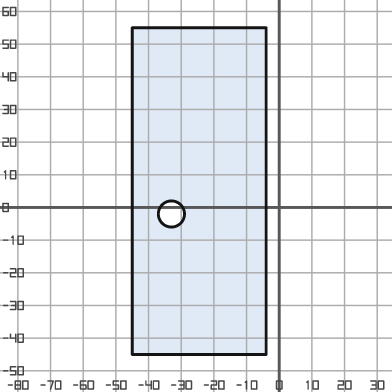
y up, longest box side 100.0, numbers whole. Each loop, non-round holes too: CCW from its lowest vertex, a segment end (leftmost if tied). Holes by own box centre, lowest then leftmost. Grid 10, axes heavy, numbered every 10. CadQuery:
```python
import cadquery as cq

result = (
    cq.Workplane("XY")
    .moveTo(-45.0, -45.0)
    .lineTo(-4.0, -45.0)
    .lineTo(-4.0, 55.0)
    .lineTo(-45.0, 55.0)
    .close()
    .moveTo(-33.0, -2.0)
    .circle(4.0)
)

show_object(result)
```